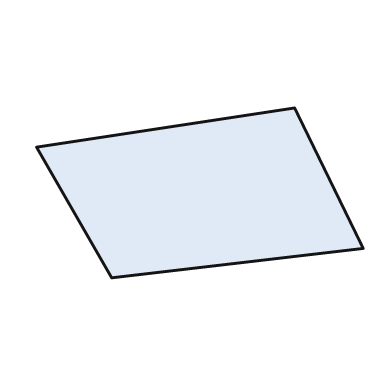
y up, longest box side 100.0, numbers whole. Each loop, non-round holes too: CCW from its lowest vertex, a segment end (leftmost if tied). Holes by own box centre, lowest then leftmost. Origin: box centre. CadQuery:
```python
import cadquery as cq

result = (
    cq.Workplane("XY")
    .moveTo(-27.0, -26.0)
    .lineTo(50.0, -17.0)
    .lineTo(29.0, 26.0)
    .lineTo(-50.0, 14.0)
    .close()
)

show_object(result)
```